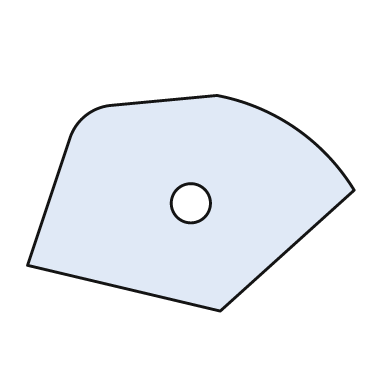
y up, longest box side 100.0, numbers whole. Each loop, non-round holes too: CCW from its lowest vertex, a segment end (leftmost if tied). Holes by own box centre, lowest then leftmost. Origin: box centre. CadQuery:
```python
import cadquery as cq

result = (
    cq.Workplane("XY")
    .moveTo(9.0, -33.0)
    .lineTo(50.0, 4.0)
    .threePointArc((32.0, 23.0), (8.0, 33.0))
    .lineTo(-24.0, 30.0)
    .threePointArc((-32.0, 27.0), (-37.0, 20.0))
    .lineTo(-50.0, -19.0)
    .close()
    .moveTo(0.0, 0.0)
    .circle(6.0)
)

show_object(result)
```